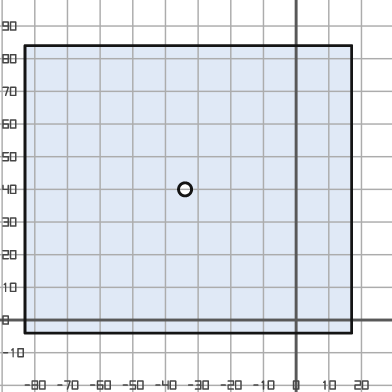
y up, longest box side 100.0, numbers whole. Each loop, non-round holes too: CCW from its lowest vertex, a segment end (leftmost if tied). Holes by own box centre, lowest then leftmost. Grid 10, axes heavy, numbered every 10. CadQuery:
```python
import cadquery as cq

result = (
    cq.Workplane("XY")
    .moveTo(-83.0, -4.0)
    .lineTo(17.0, -4.0)
    .lineTo(17.0, 84.0)
    .lineTo(-83.0, 84.0)
    .close()
    .moveTo(-34.0, 40.0)
    .circle(2.0)
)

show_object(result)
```